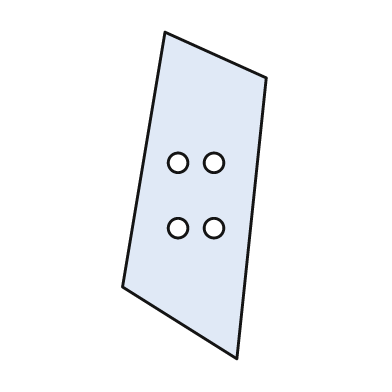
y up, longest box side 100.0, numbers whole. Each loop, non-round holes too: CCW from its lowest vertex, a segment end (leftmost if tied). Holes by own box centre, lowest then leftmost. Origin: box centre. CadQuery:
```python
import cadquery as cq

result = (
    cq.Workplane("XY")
    .moveTo(13.0, -50.0)
    .lineTo(22.0, 36.0)
    .lineTo(-9.0, 50.0)
    .lineTo(-22.0, -28.0)
    .close()
    .moveTo(-5.0, -10.0)
    .circle(3.0)
    .moveTo(6.0, -10.0)
    .circle(3.0)
    .moveTo(-5.0, 10.0)
    .circle(3.0)
    .moveTo(6.0, 10.0)
    .circle(3.0)
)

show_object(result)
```